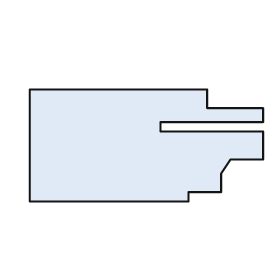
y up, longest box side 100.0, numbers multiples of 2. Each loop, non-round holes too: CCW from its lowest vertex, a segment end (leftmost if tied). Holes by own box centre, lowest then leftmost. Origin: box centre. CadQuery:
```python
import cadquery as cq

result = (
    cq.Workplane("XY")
    .moveTo(-50.0, -24.0)
    .lineTo(18.0, -24.0)
    .lineTo(18.0, -20.0)
    .lineTo(32.0, -20.0)
    .lineTo(32.0, -12.0)
    .lineTo(36.0, -6.0)
    .lineTo(50.0, -6.0)
    .lineTo(50.0, 6.0)
    .lineTo(6.0, 6.0)
    .lineTo(6.0, 10.0)
    .lineTo(50.0, 10.0)
    .lineTo(50.0, 16.0)
    .lineTo(26.0, 16.0)
    .lineTo(26.0, 24.0)
    .lineTo(-50.0, 24.0)
    .close()
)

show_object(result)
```